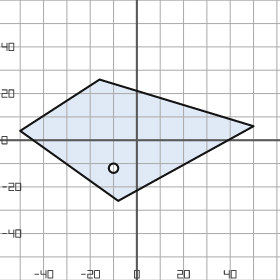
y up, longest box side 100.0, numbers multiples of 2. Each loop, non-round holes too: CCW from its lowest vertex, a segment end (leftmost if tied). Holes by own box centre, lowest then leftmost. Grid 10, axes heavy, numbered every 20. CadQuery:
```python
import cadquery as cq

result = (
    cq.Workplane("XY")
    .moveTo(-8.0, -26.0)
    .lineTo(50.0, 6.0)
    .lineTo(-16.0, 26.0)
    .lineTo(-50.0, 4.0)
    .close()
    .moveTo(-10.0, -12.0)
    .circle(2.0)
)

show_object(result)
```